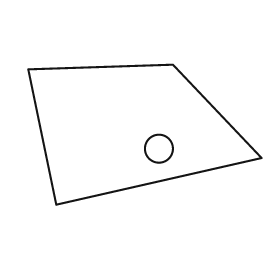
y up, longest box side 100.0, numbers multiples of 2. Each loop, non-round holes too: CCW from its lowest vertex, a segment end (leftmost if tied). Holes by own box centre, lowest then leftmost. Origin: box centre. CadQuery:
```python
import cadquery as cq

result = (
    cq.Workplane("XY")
    .moveTo(-38.0, -30.0)
    .lineTo(50.0, -10.0)
    .lineTo(12.0, 30.0)
    .lineTo(-50.0, 28.0)
    .close()
    .moveTo(6.0, -6.0)
    .circle(6.0)
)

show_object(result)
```